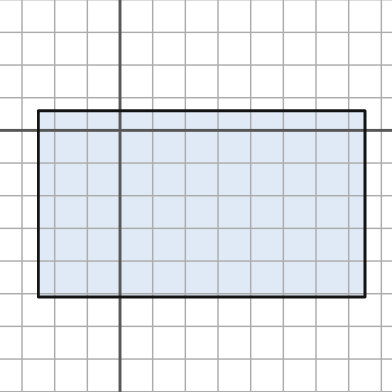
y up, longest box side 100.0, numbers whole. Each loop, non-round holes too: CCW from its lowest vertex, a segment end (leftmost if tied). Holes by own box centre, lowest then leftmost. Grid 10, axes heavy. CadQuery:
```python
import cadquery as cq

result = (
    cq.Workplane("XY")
    .moveTo(-25.0, -51.0)
    .lineTo(75.0, -51.0)
    .lineTo(75.0, 6.0)
    .lineTo(-25.0, 6.0)
    .close()
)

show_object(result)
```